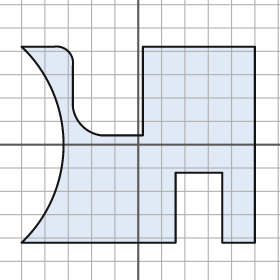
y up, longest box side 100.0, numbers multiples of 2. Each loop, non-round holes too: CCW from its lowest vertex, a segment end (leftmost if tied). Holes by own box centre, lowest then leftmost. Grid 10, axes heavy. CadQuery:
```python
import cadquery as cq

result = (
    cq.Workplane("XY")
    .moveTo(-50.0, -42.0)
    .lineTo(16.0, -42.0)
    .lineTo(16.0, -12.0)
    .lineTo(36.0, -12.0)
    .lineTo(36.0, -42.0)
    .lineTo(50.0, -42.0)
    .lineTo(50.0, 42.0)
    .lineTo(2.0, 42.0)
    .lineTo(2.0, 4.0)
    .lineTo(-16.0, 4.0)
    .threePointArc((-24.0, 8.0), (-28.0, 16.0))
    .lineTo(-28.0, 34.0)
    .threePointArc((-30.0, 40.0), (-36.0, 42.0))
    .lineTo(-50.0, 42.0)
    .threePointArc((-32.0, 0.0), (-50.0, -42.0))
    .close()
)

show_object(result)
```